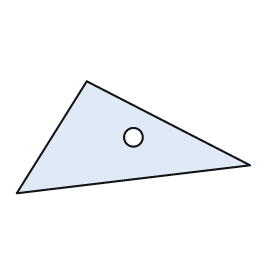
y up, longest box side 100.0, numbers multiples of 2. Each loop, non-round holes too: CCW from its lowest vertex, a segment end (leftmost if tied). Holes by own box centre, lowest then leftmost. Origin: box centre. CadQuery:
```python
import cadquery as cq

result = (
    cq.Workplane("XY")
    .moveTo(-50.0, -24.0)
    .lineTo(50.0, -12.0)
    .lineTo(-20.0, 24.0)
    .close()
    .moveTo(0.0, 0.0)
    .circle(4.0)
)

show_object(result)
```